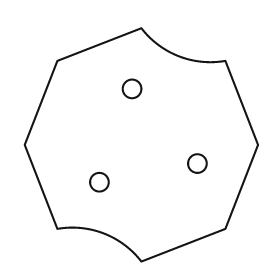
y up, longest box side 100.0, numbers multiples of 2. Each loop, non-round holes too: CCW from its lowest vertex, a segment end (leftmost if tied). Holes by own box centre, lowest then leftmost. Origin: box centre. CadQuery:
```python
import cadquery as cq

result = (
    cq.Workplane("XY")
    .moveTo(0.0, -50.0)
    .lineTo(36.0, -36.0)
    .lineTo(50.0, 0.0)
    .lineTo(36.0, 36.0)
    .threePointArc((16.0, 38.0), (0.0, 50.0))
    .lineTo(-36.0, 36.0)
    .lineTo(-50.0, 0.0)
    .lineTo(-36.0, -36.0)
    .threePointArc((-16.0, -38.0), (0.0, -50.0))
    .close()
    .moveTo(-18.0, -16.0)
    .circle(4.0)
    .moveTo(24.0, -8.0)
    .circle(4.0)
    .moveTo(-4.0, 24.0)
    .circle(4.0)
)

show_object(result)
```